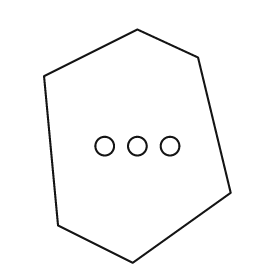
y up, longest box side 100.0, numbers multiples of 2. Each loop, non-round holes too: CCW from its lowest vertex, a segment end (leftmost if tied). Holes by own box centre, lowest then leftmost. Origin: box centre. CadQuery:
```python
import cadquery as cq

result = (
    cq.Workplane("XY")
    .moveTo(-2.0, -50.0)
    .lineTo(40.0, -20.0)
    .lineTo(26.0, 38.0)
    .lineTo(0.0, 50.0)
    .lineTo(-40.0, 30.0)
    .lineTo(-34.0, -34.0)
    .close()
    .moveTo(-14.0, 0.0)
    .circle(4.0)
    .moveTo(0.0, 0.0)
    .circle(4.0)
    .moveTo(14.0, 0.0)
    .circle(4.0)
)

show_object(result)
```